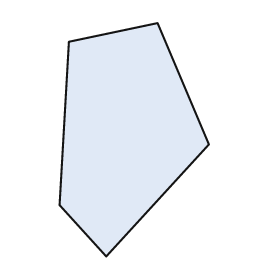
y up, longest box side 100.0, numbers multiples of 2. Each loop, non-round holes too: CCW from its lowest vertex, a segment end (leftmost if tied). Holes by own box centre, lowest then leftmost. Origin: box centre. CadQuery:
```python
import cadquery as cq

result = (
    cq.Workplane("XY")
    .moveTo(-12.0, -50.0)
    .lineTo(32.0, -2.0)
    .lineTo(10.0, 50.0)
    .lineTo(-28.0, 42.0)
    .lineTo(-32.0, -28.0)
    .close()
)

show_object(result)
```